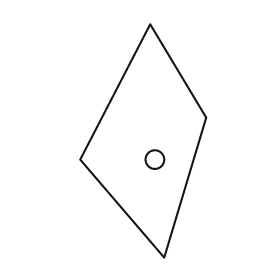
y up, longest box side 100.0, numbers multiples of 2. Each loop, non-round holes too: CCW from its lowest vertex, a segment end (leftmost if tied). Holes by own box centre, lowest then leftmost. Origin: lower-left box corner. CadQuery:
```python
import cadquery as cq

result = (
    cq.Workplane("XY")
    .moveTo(36.0, 0.0)
    .lineTo(54.0, 60.0)
    .lineTo(30.0, 100.0)
    .lineTo(0.0, 42.0)
    .close()
    .moveTo(32.0, 42.0)
    .circle(4.0)
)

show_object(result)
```